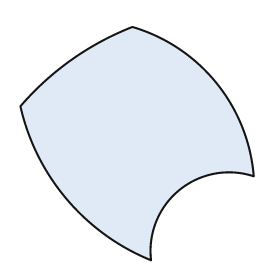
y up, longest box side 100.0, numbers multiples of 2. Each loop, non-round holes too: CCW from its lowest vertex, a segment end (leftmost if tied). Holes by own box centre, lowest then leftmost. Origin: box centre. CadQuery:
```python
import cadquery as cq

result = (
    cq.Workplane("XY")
    .moveTo(6.0, -50.0)
    .threePointArc((18.0, -20.0), (50.0, -14.0))
    .threePointArc((34.0, 26.0), (-2.0, 50.0))
    .threePointArc((-28.0, 36.0), (-50.0, 16.0))
    .threePointArc((-30.0, -24.0), (6.0, -50.0))
    .close()
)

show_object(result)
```